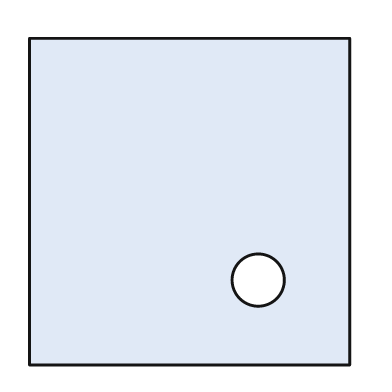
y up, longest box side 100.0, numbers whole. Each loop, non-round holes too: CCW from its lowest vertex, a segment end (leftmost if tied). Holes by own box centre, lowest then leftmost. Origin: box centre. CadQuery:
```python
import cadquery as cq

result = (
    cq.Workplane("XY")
    .moveTo(-49.0, -50.0)
    .lineTo(49.0, -50.0)
    .lineTo(49.0, 50.0)
    .lineTo(-49.0, 50.0)
    .close()
    .moveTo(21.0, -24.0)
    .circle(8.0)
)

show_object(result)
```